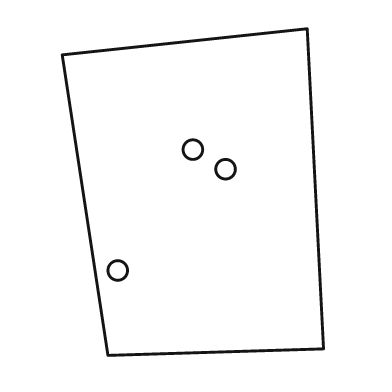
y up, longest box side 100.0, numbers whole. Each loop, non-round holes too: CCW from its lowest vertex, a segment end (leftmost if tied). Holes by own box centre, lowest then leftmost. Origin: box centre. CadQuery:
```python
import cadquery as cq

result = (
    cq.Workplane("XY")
    .moveTo(-26.0, -50.0)
    .lineTo(40.0, -48.0)
    .lineTo(35.0, 50.0)
    .lineTo(-40.0, 42.0)
    .close()
    .moveTo(-23.0, -24.0)
    .circle(3.0)
    .moveTo(10.0, 7.0)
    .circle(3.0)
    .moveTo(0.0, 13.0)
    .circle(3.0)
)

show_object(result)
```